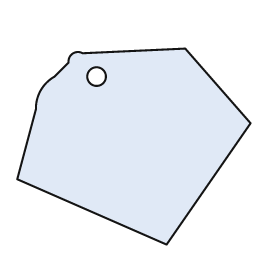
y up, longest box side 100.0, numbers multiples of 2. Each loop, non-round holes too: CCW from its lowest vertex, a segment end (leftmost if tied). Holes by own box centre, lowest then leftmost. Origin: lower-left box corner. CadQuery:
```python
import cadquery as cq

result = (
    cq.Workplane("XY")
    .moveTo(64.0, 0.0)
    .lineTo(100.0, 52.0)
    .lineTo(72.0, 84.0)
    .lineTo(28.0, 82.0)
    .threePointArc((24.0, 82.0), (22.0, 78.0))
    .lineTo(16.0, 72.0)
    .threePointArc((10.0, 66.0), (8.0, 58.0))
    .lineTo(0.0, 28.0)
    .close()
    .moveTo(34.0, 72.0)
    .circle(4.0)
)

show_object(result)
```